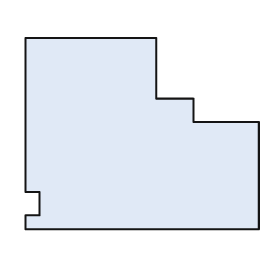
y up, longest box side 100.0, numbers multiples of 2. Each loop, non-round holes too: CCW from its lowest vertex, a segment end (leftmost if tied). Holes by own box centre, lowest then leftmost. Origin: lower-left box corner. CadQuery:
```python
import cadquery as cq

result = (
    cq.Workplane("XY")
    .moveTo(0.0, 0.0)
    .lineTo(100.0, 0.0)
    .lineTo(100.0, 46.0)
    .lineTo(72.0, 46.0)
    .lineTo(72.0, 56.0)
    .lineTo(56.0, 56.0)
    .lineTo(56.0, 82.0)
    .lineTo(0.0, 82.0)
    .lineTo(0.0, 16.0)
    .lineTo(6.0, 16.0)
    .lineTo(6.0, 6.0)
    .lineTo(0.0, 6.0)
    .close()
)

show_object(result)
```